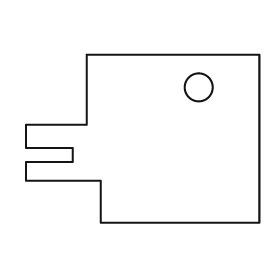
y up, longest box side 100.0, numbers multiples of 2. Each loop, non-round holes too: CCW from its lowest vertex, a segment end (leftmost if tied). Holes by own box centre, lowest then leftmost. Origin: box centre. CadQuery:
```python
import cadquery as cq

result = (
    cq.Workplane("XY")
    .moveTo(-18.0, -36.0)
    .lineTo(50.0, -36.0)
    .lineTo(50.0, 36.0)
    .lineTo(-24.0, 36.0)
    .lineTo(-24.0, 6.0)
    .lineTo(-50.0, 6.0)
    .lineTo(-50.0, -4.0)
    .lineTo(-30.0, -4.0)
    .lineTo(-30.0, -10.0)
    .lineTo(-50.0, -10.0)
    .lineTo(-50.0, -18.0)
    .lineTo(-18.0, -18.0)
    .close()
    .moveTo(24.0, 22.0)
    .circle(6.0)
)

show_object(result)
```